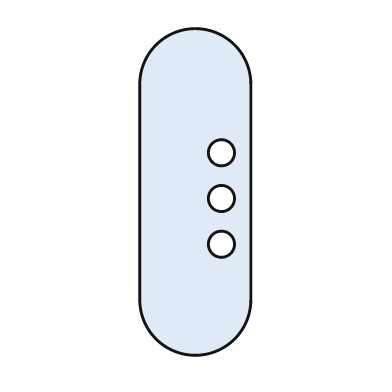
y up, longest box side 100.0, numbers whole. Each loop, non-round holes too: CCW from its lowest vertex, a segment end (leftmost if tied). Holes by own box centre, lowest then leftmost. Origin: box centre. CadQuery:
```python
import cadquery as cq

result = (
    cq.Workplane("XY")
    .moveTo(-17.0, -33.0)
    .threePointArc((0.0, -50.0), (17.0, -33.0))
    .lineTo(17.0, 33.0)
    .threePointArc((0.0, 50.0), (-17.0, 33.0))
    .close()
    .moveTo(8.0, -16.0)
    .circle(4.0)
    .moveTo(8.0, -2.0)
    .circle(4.0)
    .moveTo(8.0, 12.0)
    .circle(4.0)
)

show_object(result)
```